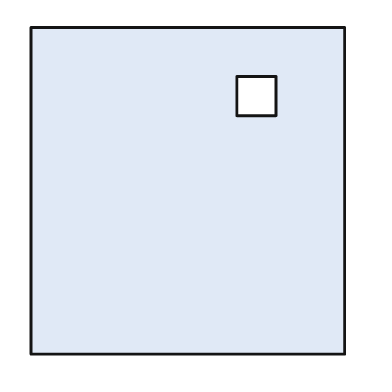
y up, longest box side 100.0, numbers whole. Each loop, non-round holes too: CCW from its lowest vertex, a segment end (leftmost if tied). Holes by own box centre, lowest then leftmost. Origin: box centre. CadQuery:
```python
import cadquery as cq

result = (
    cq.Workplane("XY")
    .moveTo(-48.0, -50.0)
    .lineTo(48.0, -50.0)
    .lineTo(48.0, 50.0)
    .lineTo(-48.0, 50.0)
    .close()
    .moveTo(15.0, 23.0)
    .lineTo(27.0, 23.0)
    .lineTo(27.0, 35.0)
    .lineTo(15.0, 35.0)
    .close()
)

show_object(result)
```